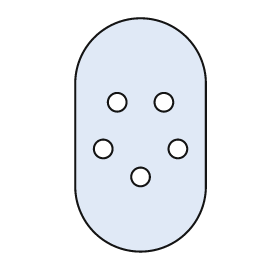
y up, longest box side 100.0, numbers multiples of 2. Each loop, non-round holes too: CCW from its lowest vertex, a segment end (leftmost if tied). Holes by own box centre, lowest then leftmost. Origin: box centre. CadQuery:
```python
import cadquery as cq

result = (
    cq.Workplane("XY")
    .moveTo(-28.0, -22.0)
    .threePointArc((0.0, -50.0), (28.0, -22.0))
    .lineTo(28.0, 22.0)
    .threePointArc((0.0, 50.0), (-28.0, 22.0))
    .close()
    .moveTo(0.0, -18.0)
    .circle(4.0)
    .moveTo(-16.0, -6.0)
    .circle(4.0)
    .moveTo(16.0, -6.0)
    .circle(4.0)
    .moveTo(-10.0, 14.0)
    .circle(4.0)
    .moveTo(10.0, 14.0)
    .circle(4.0)
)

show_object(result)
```